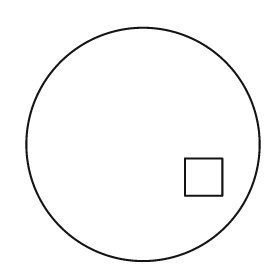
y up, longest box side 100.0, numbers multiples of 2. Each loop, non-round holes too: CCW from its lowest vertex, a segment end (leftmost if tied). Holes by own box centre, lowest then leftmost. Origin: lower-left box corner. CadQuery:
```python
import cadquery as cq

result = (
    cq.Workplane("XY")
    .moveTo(50.0, 50.0)
    .circle(50.0)
    .moveTo(68.0, 28.0)
    .lineTo(84.0, 28.0)
    .lineTo(84.0, 44.0)
    .lineTo(68.0, 44.0)
    .close()
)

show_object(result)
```